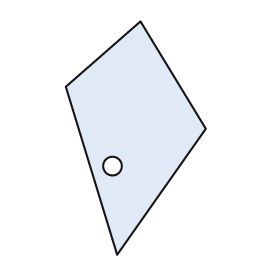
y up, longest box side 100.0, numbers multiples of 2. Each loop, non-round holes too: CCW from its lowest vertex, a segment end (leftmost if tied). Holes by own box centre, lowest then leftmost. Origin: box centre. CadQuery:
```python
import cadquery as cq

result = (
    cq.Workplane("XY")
    .moveTo(-8.0, -50.0)
    .lineTo(30.0, 4.0)
    .lineTo(2.0, 50.0)
    .lineTo(-30.0, 22.0)
    .close()
    .moveTo(-10.0, -12.0)
    .circle(4.0)
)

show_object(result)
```